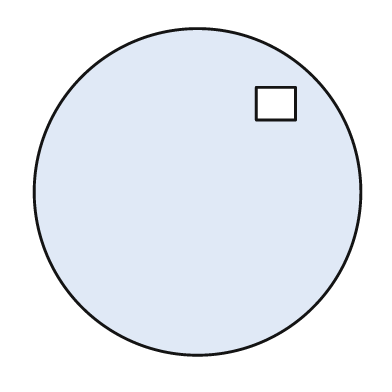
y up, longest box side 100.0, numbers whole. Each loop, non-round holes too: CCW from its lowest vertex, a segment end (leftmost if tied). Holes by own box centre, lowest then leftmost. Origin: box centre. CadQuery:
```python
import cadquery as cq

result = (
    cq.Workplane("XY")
    .moveTo(0.0, 0.0)
    .circle(50.0)
    .moveTo(18.0, 22.0)
    .lineTo(30.0, 22.0)
    .lineTo(30.0, 32.0)
    .lineTo(18.0, 32.0)
    .close()
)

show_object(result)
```